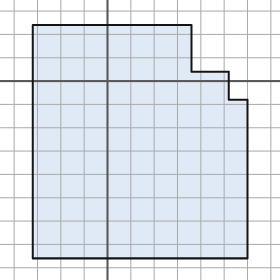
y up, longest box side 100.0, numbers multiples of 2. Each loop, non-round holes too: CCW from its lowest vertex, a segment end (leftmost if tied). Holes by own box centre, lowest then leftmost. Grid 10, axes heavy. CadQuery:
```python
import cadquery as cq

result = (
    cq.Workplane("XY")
    .moveTo(-32.0, -76.0)
    .lineTo(60.0, -76.0)
    .lineTo(60.0, -8.0)
    .lineTo(52.0, -8.0)
    .lineTo(52.0, 4.0)
    .lineTo(36.0, 4.0)
    .lineTo(36.0, 24.0)
    .lineTo(-32.0, 24.0)
    .close()
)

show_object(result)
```